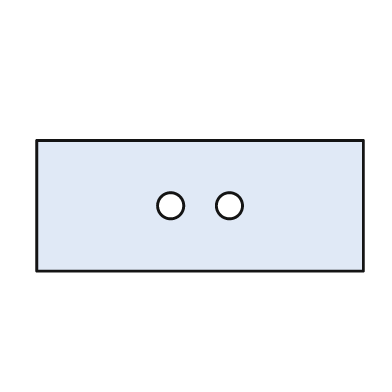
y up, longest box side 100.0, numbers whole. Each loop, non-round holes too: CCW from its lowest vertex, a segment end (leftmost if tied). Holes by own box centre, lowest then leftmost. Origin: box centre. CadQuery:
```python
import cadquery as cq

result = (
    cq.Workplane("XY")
    .moveTo(-50.0, -20.0)
    .lineTo(50.0, -20.0)
    .lineTo(50.0, 20.0)
    .lineTo(-50.0, 20.0)
    .close()
    .moveTo(-9.0, 0.0)
    .circle(4.0)
    .moveTo(9.0, 0.0)
    .circle(4.0)
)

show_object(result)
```